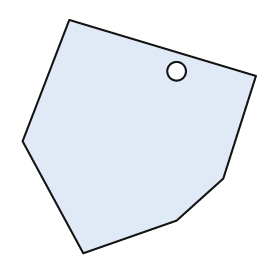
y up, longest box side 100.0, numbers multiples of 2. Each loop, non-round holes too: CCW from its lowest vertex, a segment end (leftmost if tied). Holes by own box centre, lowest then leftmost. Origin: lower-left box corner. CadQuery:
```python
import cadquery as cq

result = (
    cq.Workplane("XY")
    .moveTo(26.0, 0.0)
    .lineTo(66.0, 14.0)
    .lineTo(86.0, 32.0)
    .lineTo(100.0, 76.0)
    .lineTo(20.0, 100.0)
    .lineTo(0.0, 48.0)
    .close()
    .moveTo(66.0, 78.0)
    .circle(4.0)
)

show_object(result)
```